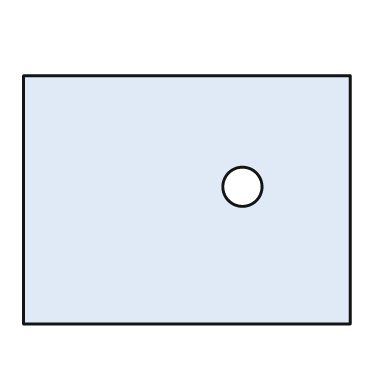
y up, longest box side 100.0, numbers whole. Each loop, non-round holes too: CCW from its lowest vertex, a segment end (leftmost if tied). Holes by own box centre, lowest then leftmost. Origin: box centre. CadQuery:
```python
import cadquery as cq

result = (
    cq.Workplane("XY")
    .moveTo(-50.0, -38.0)
    .lineTo(50.0, -38.0)
    .lineTo(50.0, 38.0)
    .lineTo(-50.0, 38.0)
    .close()
    .moveTo(17.0, 4.0)
    .circle(6.0)
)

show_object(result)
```